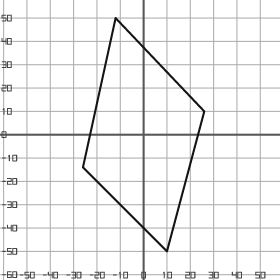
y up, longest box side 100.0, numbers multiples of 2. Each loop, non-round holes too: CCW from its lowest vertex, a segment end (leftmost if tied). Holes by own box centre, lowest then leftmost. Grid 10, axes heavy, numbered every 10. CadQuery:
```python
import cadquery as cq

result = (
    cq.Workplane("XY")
    .moveTo(10.0, -50.0)
    .lineTo(26.0, 10.0)
    .lineTo(-12.0, 50.0)
    .lineTo(-26.0, -14.0)
    .close()
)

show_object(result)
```